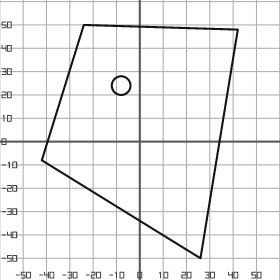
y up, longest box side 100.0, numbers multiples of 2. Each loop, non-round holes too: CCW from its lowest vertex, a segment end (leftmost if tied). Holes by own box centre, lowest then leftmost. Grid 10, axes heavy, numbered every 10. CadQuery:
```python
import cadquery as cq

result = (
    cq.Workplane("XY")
    .moveTo(26.0, -50.0)
    .lineTo(42.0, 48.0)
    .lineTo(-24.0, 50.0)
    .lineTo(-42.0, -8.0)
    .close()
    .moveTo(-8.0, 24.0)
    .circle(4.0)
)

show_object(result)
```